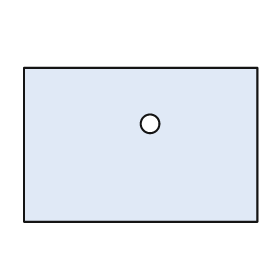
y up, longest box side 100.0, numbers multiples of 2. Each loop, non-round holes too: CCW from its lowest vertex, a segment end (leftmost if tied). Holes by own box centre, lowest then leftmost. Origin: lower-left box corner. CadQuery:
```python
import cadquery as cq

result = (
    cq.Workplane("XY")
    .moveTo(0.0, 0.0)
    .lineTo(100.0, 0.0)
    .lineTo(100.0, 66.0)
    .lineTo(0.0, 66.0)
    .close()
    .moveTo(54.0, 42.0)
    .circle(4.0)
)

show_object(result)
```